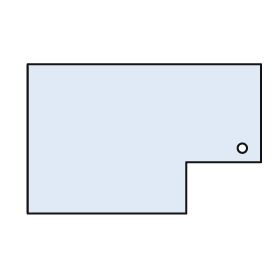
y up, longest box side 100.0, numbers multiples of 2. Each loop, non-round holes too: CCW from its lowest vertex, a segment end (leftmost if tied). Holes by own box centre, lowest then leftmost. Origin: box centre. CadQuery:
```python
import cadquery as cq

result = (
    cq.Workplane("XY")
    .moveTo(-50.0, -32.0)
    .lineTo(18.0, -32.0)
    .lineTo(18.0, -10.0)
    .lineTo(50.0, -10.0)
    .lineTo(50.0, 32.0)
    .lineTo(-50.0, 32.0)
    .close()
    .moveTo(42.0, -4.0)
    .circle(2.0)
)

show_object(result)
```